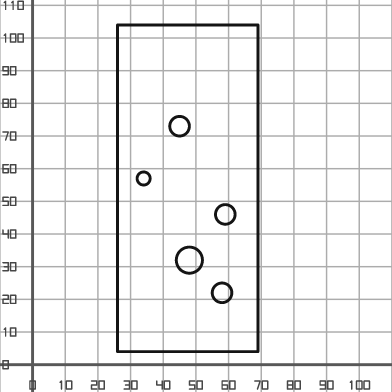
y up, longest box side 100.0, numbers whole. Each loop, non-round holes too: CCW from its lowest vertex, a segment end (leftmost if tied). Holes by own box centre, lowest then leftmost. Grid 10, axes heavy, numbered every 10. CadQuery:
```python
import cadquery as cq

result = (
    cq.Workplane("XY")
    .moveTo(26.0, 4.0)
    .lineTo(69.0, 4.0)
    .lineTo(69.0, 104.0)
    .lineTo(26.0, 104.0)
    .close()
    .moveTo(58.0, 22.0)
    .circle(3.0)
    .moveTo(48.0, 32.0)
    .circle(4.0)
    .moveTo(59.0, 46.0)
    .circle(3.0)
    .moveTo(34.0, 57.0)
    .circle(2.0)
    .moveTo(45.0, 73.0)
    .circle(3.0)
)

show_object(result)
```